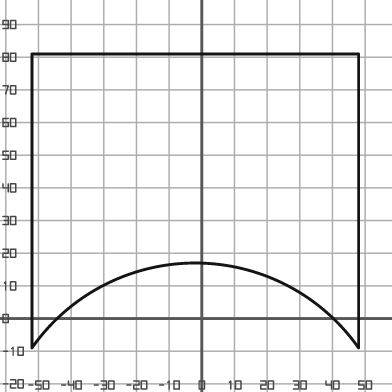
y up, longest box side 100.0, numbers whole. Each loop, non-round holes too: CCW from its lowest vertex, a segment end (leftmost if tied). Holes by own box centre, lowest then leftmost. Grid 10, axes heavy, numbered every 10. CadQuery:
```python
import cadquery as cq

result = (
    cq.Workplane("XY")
    .moveTo(-52.0, -9.0)
    .threePointArc((-2.0, 17.0), (48.0, -9.0))
    .lineTo(48.0, 81.0)
    .lineTo(-52.0, 81.0)
    .close()
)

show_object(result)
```